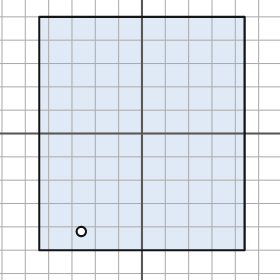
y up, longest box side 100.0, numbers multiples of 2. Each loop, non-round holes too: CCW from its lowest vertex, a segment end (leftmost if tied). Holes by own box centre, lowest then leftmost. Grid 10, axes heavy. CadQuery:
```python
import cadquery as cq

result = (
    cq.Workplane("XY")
    .moveTo(-44.0, -50.0)
    .lineTo(44.0, -50.0)
    .lineTo(44.0, 50.0)
    .lineTo(-44.0, 50.0)
    .close()
    .moveTo(-26.0, -42.0)
    .circle(2.0)
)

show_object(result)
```